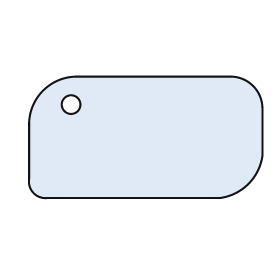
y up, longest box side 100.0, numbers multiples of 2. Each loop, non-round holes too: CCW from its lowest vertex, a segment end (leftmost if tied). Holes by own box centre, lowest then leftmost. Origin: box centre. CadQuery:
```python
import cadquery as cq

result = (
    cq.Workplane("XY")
    .moveTo(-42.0, -26.0)
    .lineTo(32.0, -26.0)
    .threePointArc((44.0, -20.0), (50.0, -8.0))
    .lineTo(50.0, 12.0)
    .threePointArc((46.0, 22.0), (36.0, 26.0))
    .lineTo(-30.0, 26.0)
    .threePointArc((-44.0, 20.0), (-50.0, 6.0))
    .lineTo(-50.0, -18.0)
    .threePointArc((-48.0, -24.0), (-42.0, -26.0))
    .close()
    .moveTo(-32.0, 14.0)
    .circle(4.0)
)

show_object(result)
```